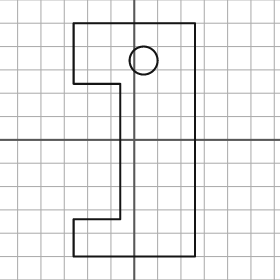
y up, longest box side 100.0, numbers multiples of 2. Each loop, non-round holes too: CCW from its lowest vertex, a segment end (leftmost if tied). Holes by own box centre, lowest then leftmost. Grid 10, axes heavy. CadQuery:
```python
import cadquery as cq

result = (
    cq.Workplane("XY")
    .moveTo(-26.0, -50.0)
    .lineTo(26.0, -50.0)
    .lineTo(26.0, 50.0)
    .lineTo(-26.0, 50.0)
    .lineTo(-26.0, 24.0)
    .lineTo(-6.0, 24.0)
    .lineTo(-6.0, -34.0)
    .lineTo(-26.0, -34.0)
    .close()
    .moveTo(4.0, 34.0)
    .circle(6.0)
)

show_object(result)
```